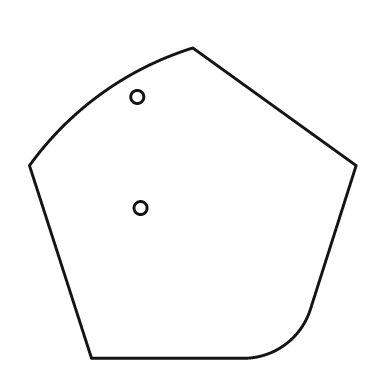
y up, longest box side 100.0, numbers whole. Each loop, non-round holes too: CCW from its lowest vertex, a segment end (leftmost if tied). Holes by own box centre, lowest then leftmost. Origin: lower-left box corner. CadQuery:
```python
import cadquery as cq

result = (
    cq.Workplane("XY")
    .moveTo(19.0, 0.0)
    .lineTo(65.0, 0.0)
    .threePointArc((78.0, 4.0), (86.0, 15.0))
    .lineTo(100.0, 59.0)
    .lineTo(50.0, 95.0)
    .threePointArc((22.0, 81.0), (0.0, 59.0))
    .close()
    .moveTo(34.0, 46.0)
    .circle(2.0)
    .moveTo(33.0, 80.0)
    .circle(2.0)
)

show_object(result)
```